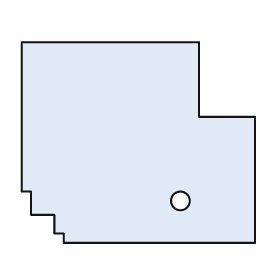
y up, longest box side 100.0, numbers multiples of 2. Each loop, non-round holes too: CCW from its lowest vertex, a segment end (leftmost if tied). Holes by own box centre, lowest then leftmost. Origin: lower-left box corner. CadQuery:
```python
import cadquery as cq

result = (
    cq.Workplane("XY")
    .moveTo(18.0, 0.0)
    .lineTo(100.0, 0.0)
    .lineTo(100.0, 54.0)
    .lineTo(76.0, 54.0)
    .lineTo(76.0, 86.0)
    .lineTo(0.0, 86.0)
    .lineTo(0.0, 22.0)
    .lineTo(4.0, 22.0)
    .lineTo(4.0, 12.0)
    .lineTo(14.0, 12.0)
    .lineTo(14.0, 4.0)
    .lineTo(18.0, 4.0)
    .close()
    .moveTo(68.0, 18.0)
    .circle(4.0)
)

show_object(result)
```